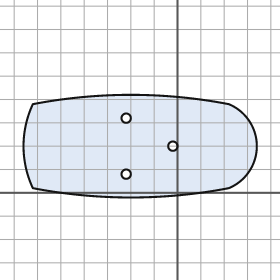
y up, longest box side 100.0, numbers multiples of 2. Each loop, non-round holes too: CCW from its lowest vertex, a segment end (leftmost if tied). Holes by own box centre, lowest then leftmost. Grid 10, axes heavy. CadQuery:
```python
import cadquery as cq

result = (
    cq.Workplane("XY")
    .moveTo(-62.0, 2.0)
    .threePointArc((-20.0, -2.0), (22.0, 2.0))
    .threePointArc((34.0, 20.0), (22.0, 38.0))
    .threePointArc((-20.0, 42.0), (-62.0, 38.0))
    .threePointArc((-66.0, 20.0), (-62.0, 2.0))
    .close()
    .moveTo(-22.0, 8.0)
    .circle(2.0)
    .moveTo(-2.0, 20.0)
    .circle(2.0)
    .moveTo(-22.0, 32.0)
    .circle(2.0)
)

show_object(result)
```